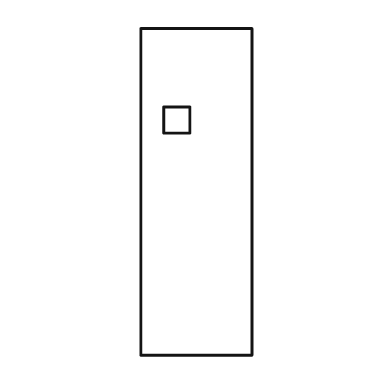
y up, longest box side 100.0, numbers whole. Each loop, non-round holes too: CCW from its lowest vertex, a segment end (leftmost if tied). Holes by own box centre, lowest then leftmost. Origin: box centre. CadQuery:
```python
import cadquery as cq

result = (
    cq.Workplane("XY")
    .moveTo(-17.0, -50.0)
    .lineTo(17.0, -50.0)
    .lineTo(17.0, 50.0)
    .lineTo(-17.0, 50.0)
    .close()
    .moveTo(-10.0, 18.0)
    .lineTo(-2.0, 18.0)
    .lineTo(-2.0, 26.0)
    .lineTo(-10.0, 26.0)
    .close()
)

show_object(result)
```